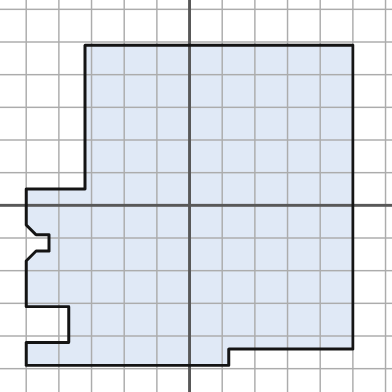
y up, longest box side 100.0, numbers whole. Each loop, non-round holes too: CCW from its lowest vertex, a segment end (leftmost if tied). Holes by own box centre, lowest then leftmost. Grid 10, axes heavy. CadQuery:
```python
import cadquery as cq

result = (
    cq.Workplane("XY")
    .moveTo(-50.0, -49.0)
    .lineTo(12.0, -49.0)
    .lineTo(12.0, -44.0)
    .lineTo(50.0, -44.0)
    .lineTo(50.0, 49.0)
    .lineTo(-32.0, 49.0)
    .lineTo(-32.0, 5.0)
    .lineTo(-50.0, 5.0)
    .lineTo(-50.0, -6.0)
    .lineTo(-47.0, -9.0)
    .lineTo(-43.0, -9.0)
    .lineTo(-43.0, -14.0)
    .lineTo(-47.0, -14.0)
    .lineTo(-50.0, -17.0)
    .lineTo(-50.0, -31.0)
    .lineTo(-37.0, -31.0)
    .lineTo(-37.0, -42.0)
    .lineTo(-50.0, -42.0)
    .close()
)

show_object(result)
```